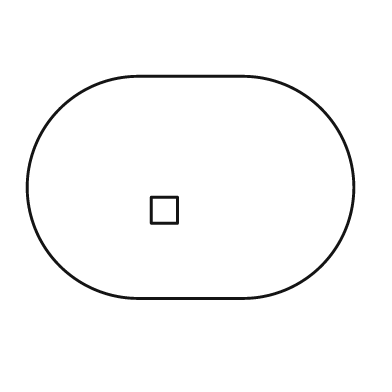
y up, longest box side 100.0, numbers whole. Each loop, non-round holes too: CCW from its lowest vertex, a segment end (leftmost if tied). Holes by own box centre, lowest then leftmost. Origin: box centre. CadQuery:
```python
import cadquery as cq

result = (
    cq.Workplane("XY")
    .moveTo(-16.0, -34.0)
    .lineTo(16.0, -34.0)
    .threePointArc((50.0, 0.0), (16.0, 34.0))
    .lineTo(-16.0, 34.0)
    .threePointArc((-50.0, 0.0), (-16.0, -34.0))
    .close()
    .moveTo(-12.0, -11.0)
    .lineTo(-4.0, -11.0)
    .lineTo(-4.0, -3.0)
    .lineTo(-12.0, -3.0)
    .close()
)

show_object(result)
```